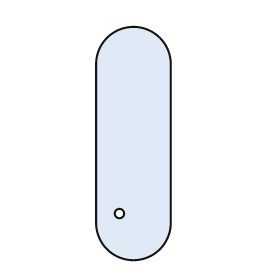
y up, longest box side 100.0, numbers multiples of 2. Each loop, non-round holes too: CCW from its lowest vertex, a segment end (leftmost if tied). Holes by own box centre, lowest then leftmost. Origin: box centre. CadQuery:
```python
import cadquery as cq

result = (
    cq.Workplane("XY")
    .moveTo(-16.0, -34.0)
    .threePointArc((0.0, -50.0), (16.0, -34.0))
    .lineTo(16.0, 34.0)
    .threePointArc((0.0, 50.0), (-16.0, 34.0))
    .close()
    .moveTo(-6.0, -30.0)
    .circle(2.0)
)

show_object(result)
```